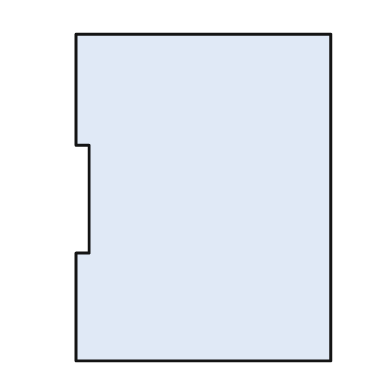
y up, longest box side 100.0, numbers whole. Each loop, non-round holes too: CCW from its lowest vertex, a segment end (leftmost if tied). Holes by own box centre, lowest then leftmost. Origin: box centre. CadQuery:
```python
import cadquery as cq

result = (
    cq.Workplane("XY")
    .moveTo(-39.0, -50.0)
    .lineTo(39.0, -50.0)
    .lineTo(39.0, 50.0)
    .lineTo(-39.0, 50.0)
    .lineTo(-39.0, 16.0)
    .lineTo(-35.0, 16.0)
    .lineTo(-35.0, -17.0)
    .lineTo(-39.0, -17.0)
    .close()
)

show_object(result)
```